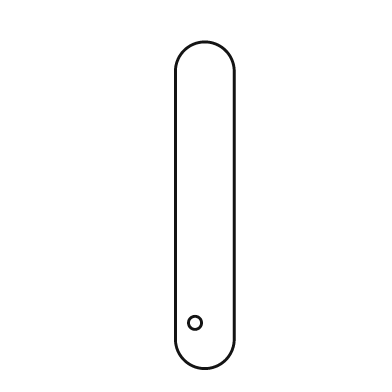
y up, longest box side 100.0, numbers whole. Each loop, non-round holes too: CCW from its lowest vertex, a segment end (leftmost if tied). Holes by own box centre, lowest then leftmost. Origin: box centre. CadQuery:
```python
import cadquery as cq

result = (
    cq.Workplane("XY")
    .moveTo(-9.0, -41.0)
    .threePointArc((0.0, -50.0), (9.0, -41.0))
    .lineTo(9.0, 41.0)
    .threePointArc((0.0, 50.0), (-9.0, 41.0))
    .close()
    .moveTo(-3.0, -36.0)
    .circle(2.0)
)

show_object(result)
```